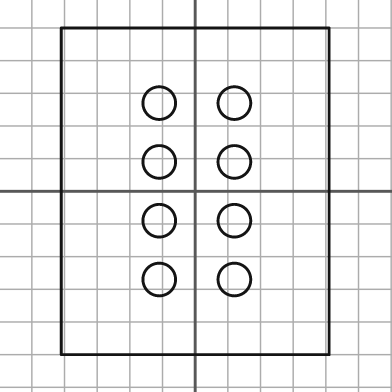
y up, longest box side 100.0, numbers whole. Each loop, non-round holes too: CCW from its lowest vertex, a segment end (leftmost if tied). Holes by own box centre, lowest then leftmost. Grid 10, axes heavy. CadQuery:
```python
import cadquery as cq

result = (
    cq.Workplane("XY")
    .moveTo(-41.0, -50.0)
    .lineTo(41.0, -50.0)
    .lineTo(41.0, 50.0)
    .lineTo(-41.0, 50.0)
    .close()
    .moveTo(-11.0, -27.0)
    .circle(5.0)
    .moveTo(12.0, -27.0)
    .circle(5.0)
    .moveTo(-11.0, -9.0)
    .circle(5.0)
    .moveTo(12.0, -9.0)
    .circle(5.0)
    .moveTo(-11.0, 9.0)
    .circle(5.0)
    .moveTo(12.0, 9.0)
    .circle(5.0)
    .moveTo(-11.0, 27.0)
    .circle(5.0)
    .moveTo(12.0, 27.0)
    .circle(5.0)
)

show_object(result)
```